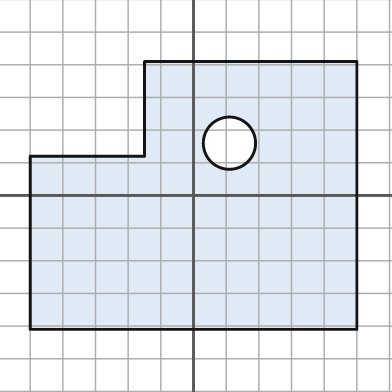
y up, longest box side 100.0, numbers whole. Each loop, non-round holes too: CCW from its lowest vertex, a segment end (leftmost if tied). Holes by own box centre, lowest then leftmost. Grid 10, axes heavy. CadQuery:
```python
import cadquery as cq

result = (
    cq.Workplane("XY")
    .moveTo(-50.0, -41.0)
    .lineTo(50.0, -41.0)
    .lineTo(50.0, 41.0)
    .lineTo(-15.0, 41.0)
    .lineTo(-15.0, 12.0)
    .lineTo(-50.0, 12.0)
    .close()
    .moveTo(11.0, 16.0)
    .circle(8.0)
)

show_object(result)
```